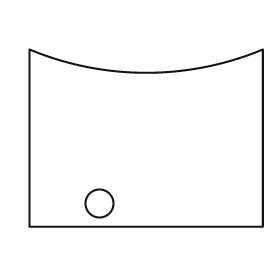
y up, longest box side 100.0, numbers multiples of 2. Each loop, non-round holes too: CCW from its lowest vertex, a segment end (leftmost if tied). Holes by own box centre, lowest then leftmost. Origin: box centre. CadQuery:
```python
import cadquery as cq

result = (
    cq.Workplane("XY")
    .moveTo(-50.0, -38.0)
    .lineTo(50.0, -38.0)
    .lineTo(50.0, 38.0)
    .threePointArc((0.0, 28.0), (-50.0, 38.0))
    .close()
    .moveTo(-20.0, -28.0)
    .circle(6.0)
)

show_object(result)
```